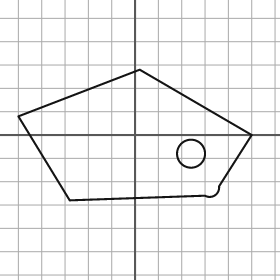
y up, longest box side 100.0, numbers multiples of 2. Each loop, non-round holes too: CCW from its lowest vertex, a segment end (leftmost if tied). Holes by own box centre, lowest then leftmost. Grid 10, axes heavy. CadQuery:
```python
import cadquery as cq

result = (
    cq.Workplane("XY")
    .moveTo(-28.0, -28.0)
    .lineTo(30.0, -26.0)
    .threePointArc((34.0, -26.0), (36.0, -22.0))
    .lineTo(50.0, 0.0)
    .lineTo(2.0, 28.0)
    .lineTo(-50.0, 8.0)
    .close()
    .moveTo(24.0, -8.0)
    .circle(6.0)
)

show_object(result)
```